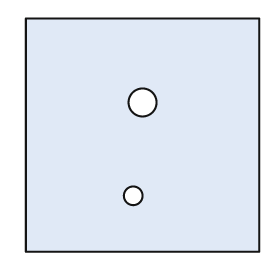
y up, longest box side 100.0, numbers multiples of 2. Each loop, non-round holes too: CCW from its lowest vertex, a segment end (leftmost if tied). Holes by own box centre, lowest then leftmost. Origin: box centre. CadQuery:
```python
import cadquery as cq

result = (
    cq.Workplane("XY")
    .moveTo(-50.0, -50.0)
    .lineTo(50.0, -50.0)
    .lineTo(50.0, 50.0)
    .lineTo(-50.0, 50.0)
    .close()
    .moveTo(-4.0, -26.0)
    .circle(4.0)
    .moveTo(0.0, 14.0)
    .circle(6.0)
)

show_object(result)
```